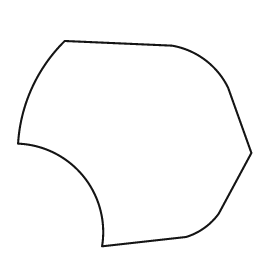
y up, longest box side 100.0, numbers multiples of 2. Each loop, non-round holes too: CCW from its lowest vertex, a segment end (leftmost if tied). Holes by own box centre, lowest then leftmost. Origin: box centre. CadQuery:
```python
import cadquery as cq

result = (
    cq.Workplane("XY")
    .moveTo(-14.0, -44.0)
    .lineTo(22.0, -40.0)
    .threePointArc((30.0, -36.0), (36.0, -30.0))
    .lineTo(50.0, -4.0)
    .lineTo(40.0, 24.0)
    .threePointArc((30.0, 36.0), (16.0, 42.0))
    .lineTo(-30.0, 44.0)
    .threePointArc((-44.0, 24.0), (-50.0, 0.0))
    .threePointArc((-22.0, -14.0), (-14.0, -44.0))
    .close()
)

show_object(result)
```